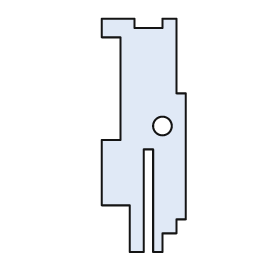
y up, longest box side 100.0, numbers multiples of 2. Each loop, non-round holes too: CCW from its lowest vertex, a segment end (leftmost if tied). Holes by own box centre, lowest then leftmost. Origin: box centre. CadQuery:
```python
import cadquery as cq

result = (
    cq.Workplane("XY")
    .moveTo(-6.0, -50.0)
    .lineTo(0.0, -50.0)
    .lineTo(0.0, -6.0)
    .lineTo(4.0, -6.0)
    .lineTo(4.0, -50.0)
    .lineTo(8.0, -50.0)
    .lineTo(8.0, -42.0)
    .lineTo(14.0, -42.0)
    .lineTo(14.0, -36.0)
    .lineTo(18.0, -36.0)
    .lineTo(18.0, 18.0)
    .lineTo(14.0, 18.0)
    .lineTo(14.0, 50.0)
    .lineTo(8.0, 50.0)
    .lineTo(8.0, 46.0)
    .lineTo(-4.0, 46.0)
    .lineTo(-4.0, 50.0)
    .lineTo(-18.0, 50.0)
    .lineTo(-18.0, 42.0)
    .lineTo(-10.0, 42.0)
    .lineTo(-10.0, -2.0)
    .lineTo(-18.0, -2.0)
    .lineTo(-18.0, -30.0)
    .lineTo(-6.0, -30.0)
    .close()
    .moveTo(8.0, 4.0)
    .circle(4.0)
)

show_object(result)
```